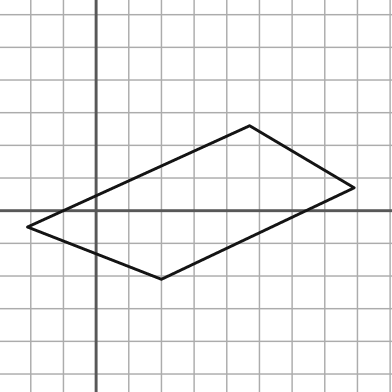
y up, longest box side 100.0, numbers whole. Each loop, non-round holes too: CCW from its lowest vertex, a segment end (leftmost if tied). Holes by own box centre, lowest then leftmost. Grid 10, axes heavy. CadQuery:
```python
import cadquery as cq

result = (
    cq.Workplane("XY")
    .moveTo(20.0, -21.0)
    .lineTo(79.0, 7.0)
    .lineTo(47.0, 26.0)
    .lineTo(-21.0, -5.0)
    .close()
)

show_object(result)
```